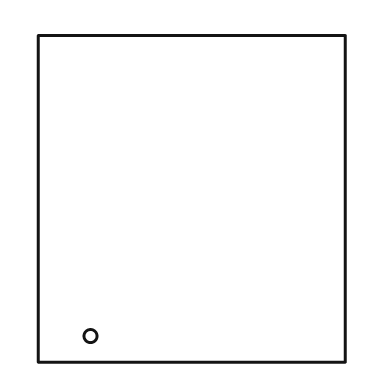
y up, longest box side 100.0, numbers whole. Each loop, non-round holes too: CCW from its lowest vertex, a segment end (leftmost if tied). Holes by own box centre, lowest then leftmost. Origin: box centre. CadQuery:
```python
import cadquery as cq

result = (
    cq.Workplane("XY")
    .moveTo(-47.0, -50.0)
    .lineTo(47.0, -50.0)
    .lineTo(47.0, 50.0)
    .lineTo(-47.0, 50.0)
    .close()
    .moveTo(-31.0, -42.0)
    .circle(2.0)
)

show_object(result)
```